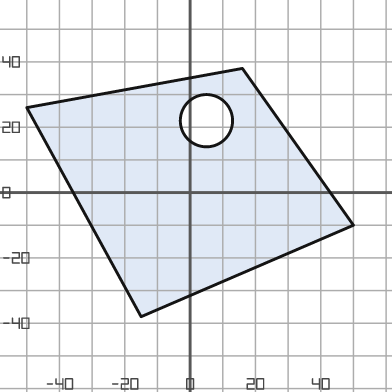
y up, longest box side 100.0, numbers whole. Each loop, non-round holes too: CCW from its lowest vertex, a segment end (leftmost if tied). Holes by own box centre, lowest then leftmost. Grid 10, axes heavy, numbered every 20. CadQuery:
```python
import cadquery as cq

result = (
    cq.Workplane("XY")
    .moveTo(-15.0, -38.0)
    .lineTo(50.0, -10.0)
    .lineTo(16.0, 38.0)
    .lineTo(-50.0, 26.0)
    .close()
    .moveTo(5.0, 22.0)
    .circle(8.0)
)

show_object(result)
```